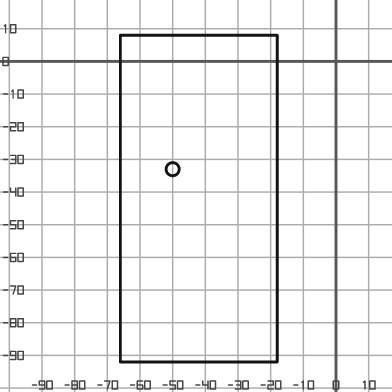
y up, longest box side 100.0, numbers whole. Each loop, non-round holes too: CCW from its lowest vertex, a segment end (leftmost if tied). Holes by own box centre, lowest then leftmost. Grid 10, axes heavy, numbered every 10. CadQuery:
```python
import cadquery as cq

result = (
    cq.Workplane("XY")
    .moveTo(-66.0, -92.0)
    .lineTo(-18.0, -92.0)
    .lineTo(-18.0, 8.0)
    .lineTo(-66.0, 8.0)
    .close()
    .moveTo(-50.0, -33.0)
    .circle(2.0)
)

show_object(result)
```